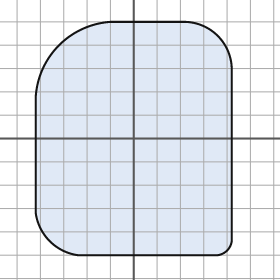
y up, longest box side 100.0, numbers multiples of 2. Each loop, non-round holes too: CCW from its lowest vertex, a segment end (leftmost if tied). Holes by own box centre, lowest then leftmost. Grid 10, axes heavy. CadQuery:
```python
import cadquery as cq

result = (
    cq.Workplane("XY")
    .moveTo(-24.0, -50.0)
    .lineTo(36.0, -50.0)
    .threePointArc((40.0, -48.0), (42.0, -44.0))
    .lineTo(42.0, 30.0)
    .threePointArc((36.0, 44.0), (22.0, 50.0))
    .lineTo(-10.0, 50.0)
    .threePointArc((-32.0, 40.0), (-42.0, 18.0))
    .lineTo(-42.0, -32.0)
    .threePointArc((-36.0, -44.0), (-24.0, -50.0))
    .close()
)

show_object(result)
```